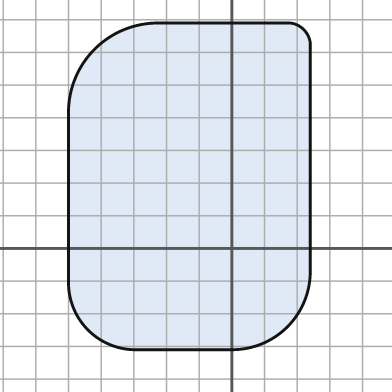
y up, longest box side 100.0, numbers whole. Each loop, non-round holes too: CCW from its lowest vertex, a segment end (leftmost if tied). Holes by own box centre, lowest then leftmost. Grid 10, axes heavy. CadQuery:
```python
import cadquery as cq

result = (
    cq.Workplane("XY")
    .moveTo(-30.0, -31.0)
    .lineTo(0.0, -31.0)
    .threePointArc((17.0, -24.0), (24.0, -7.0))
    .lineTo(24.0, 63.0)
    .threePointArc((22.0, 67.0), (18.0, 69.0))
    .lineTo(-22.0, 69.0)
    .threePointArc((-42.0, 61.0), (-50.0, 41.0))
    .lineTo(-50.0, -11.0)
    .threePointArc((-44.0, -25.0), (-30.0, -31.0))
    .close()
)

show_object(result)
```